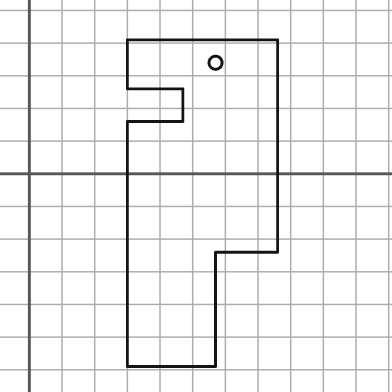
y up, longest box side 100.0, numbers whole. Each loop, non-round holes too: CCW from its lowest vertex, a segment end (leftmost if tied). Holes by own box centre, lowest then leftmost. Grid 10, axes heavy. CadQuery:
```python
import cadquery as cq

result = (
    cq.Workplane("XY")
    .moveTo(30.0, -59.0)
    .lineTo(57.0, -59.0)
    .lineTo(57.0, -24.0)
    .lineTo(76.0, -24.0)
    .lineTo(76.0, 41.0)
    .lineTo(30.0, 41.0)
    .lineTo(30.0, 26.0)
    .lineTo(47.0, 26.0)
    .lineTo(47.0, 16.0)
    .lineTo(30.0, 16.0)
    .close()
    .moveTo(57.0, 34.0)
    .circle(2.0)
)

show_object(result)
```